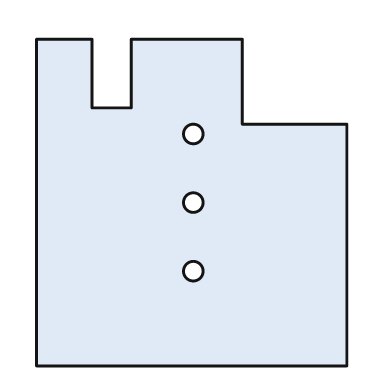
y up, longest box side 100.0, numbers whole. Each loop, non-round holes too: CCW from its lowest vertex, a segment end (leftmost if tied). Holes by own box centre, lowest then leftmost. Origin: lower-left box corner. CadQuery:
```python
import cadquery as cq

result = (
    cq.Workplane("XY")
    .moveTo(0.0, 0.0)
    .lineTo(95.0, 0.0)
    .lineTo(95.0, 74.0)
    .lineTo(63.0, 74.0)
    .lineTo(63.0, 100.0)
    .lineTo(29.0, 100.0)
    .lineTo(29.0, 79.0)
    .lineTo(17.0, 79.0)
    .lineTo(17.0, 100.0)
    .lineTo(0.0, 100.0)
    .close()
    .moveTo(48.0, 29.0)
    .circle(3.0)
    .moveTo(48.0, 50.0)
    .circle(3.0)
    .moveTo(48.0, 71.0)
    .circle(3.0)
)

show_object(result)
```